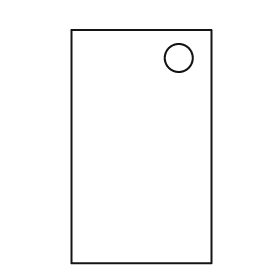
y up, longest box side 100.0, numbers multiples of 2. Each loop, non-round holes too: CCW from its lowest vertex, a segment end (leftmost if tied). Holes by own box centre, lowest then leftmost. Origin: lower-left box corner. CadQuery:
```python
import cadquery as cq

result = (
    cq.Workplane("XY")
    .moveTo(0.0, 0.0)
    .lineTo(60.0, 0.0)
    .lineTo(60.0, 100.0)
    .lineTo(0.0, 100.0)
    .close()
    .moveTo(46.0, 88.0)
    .circle(6.0)
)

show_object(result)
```